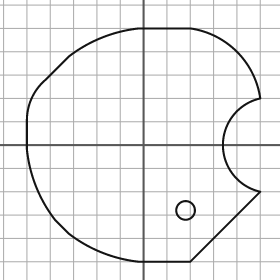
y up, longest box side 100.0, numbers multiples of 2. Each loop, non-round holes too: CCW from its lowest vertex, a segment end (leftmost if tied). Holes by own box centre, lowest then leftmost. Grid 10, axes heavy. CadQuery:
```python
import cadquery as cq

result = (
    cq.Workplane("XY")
    .moveTo(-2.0, -50.0)
    .lineTo(20.0, -50.0)
    .lineTo(50.0, -20.0)
    .threePointArc((34.0, 0.0), (50.0, 20.0))
    .threePointArc((40.0, 40.0), (20.0, 50.0))
    .lineTo(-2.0, 50.0)
    .threePointArc((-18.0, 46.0), (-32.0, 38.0))
    .lineTo(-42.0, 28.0)
    .threePointArc((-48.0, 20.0), (-50.0, 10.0))
    .lineTo(-50.0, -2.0)
    .threePointArc((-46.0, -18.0), (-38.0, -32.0))
    .lineTo(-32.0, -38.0)
    .threePointArc((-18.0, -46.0), (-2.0, -50.0))
    .close()
    .moveTo(18.0, -28.0)
    .circle(4.0)
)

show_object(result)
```